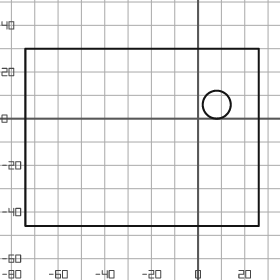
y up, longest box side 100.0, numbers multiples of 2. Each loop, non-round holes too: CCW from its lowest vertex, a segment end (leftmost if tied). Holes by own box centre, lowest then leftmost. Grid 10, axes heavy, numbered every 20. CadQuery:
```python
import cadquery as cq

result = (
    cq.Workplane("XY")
    .moveTo(-74.0, -46.0)
    .lineTo(26.0, -46.0)
    .lineTo(26.0, 30.0)
    .lineTo(-74.0, 30.0)
    .close()
    .moveTo(8.0, 6.0)
    .circle(6.0)
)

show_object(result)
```